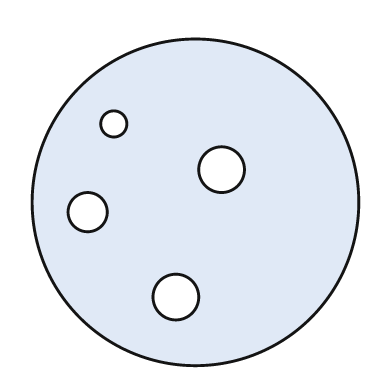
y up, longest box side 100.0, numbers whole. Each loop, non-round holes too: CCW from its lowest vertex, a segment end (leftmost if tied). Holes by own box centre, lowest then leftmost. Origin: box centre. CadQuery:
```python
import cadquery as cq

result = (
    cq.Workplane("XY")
    .moveTo(0.0, 0.0)
    .circle(50.0)
    .moveTo(-6.0, -29.0)
    .circle(7.0)
    .moveTo(-33.0, -3.0)
    .circle(6.0)
    .moveTo(8.0, 10.0)
    .circle(7.0)
    .moveTo(-25.0, 24.0)
    .circle(4.0)
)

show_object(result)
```